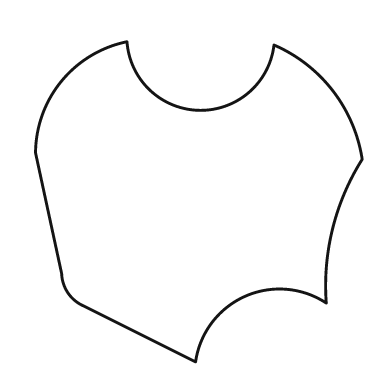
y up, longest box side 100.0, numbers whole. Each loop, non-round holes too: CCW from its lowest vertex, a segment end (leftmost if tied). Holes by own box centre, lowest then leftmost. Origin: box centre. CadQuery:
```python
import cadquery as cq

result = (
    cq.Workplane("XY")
    .moveTo(-1.0, -49.0)
    .threePointArc((14.0, -29.0), (39.0, -31.0))
    .threePointArc((41.0, -8.0), (50.0, 13.0))
    .threePointArc((41.0, 34.0), (23.0, 48.0))
    .threePointArc((0.0, 28.0), (-22.0, 49.0))
    .threePointArc((-42.0, 37.0), (-50.0, 15.0))
    .lineTo(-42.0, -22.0)
    .threePointArc((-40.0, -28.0), (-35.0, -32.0))
    .close()
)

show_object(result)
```